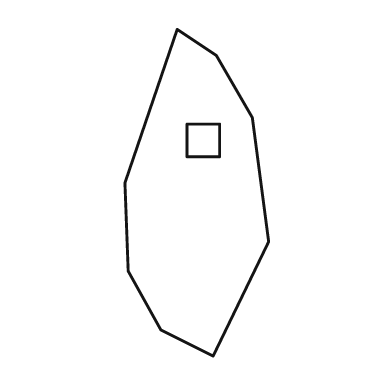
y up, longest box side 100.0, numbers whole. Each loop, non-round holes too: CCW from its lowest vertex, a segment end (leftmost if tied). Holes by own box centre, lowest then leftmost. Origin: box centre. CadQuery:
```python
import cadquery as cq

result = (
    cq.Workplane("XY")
    .moveTo(5.0, -50.0)
    .lineTo(22.0, -15.0)
    .lineTo(17.0, 23.0)
    .lineTo(6.0, 42.0)
    .lineTo(-6.0, 50.0)
    .lineTo(-22.0, 3.0)
    .lineTo(-21.0, -24.0)
    .lineTo(-11.0, -42.0)
    .close()
    .moveTo(-3.0, 11.0)
    .lineTo(7.0, 11.0)
    .lineTo(7.0, 21.0)
    .lineTo(-3.0, 21.0)
    .close()
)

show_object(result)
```